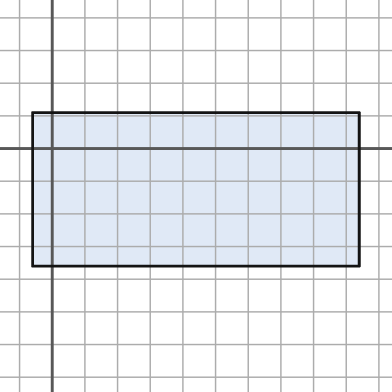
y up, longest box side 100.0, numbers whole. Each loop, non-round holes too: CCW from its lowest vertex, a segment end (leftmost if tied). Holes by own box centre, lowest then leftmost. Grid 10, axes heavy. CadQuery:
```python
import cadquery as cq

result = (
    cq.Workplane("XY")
    .moveTo(-6.0, -36.0)
    .lineTo(94.0, -36.0)
    .lineTo(94.0, 11.0)
    .lineTo(-6.0, 11.0)
    .close()
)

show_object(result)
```